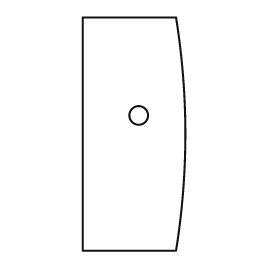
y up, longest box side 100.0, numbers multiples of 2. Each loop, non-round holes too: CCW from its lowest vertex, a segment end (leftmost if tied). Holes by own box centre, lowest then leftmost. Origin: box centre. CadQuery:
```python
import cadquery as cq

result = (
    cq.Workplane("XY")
    .moveTo(-22.0, -50.0)
    .lineTo(18.0, -50.0)
    .threePointArc((22.0, 0.0), (18.0, 50.0))
    .lineTo(-22.0, 50.0)
    .close()
    .moveTo(2.0, 8.0)
    .circle(4.0)
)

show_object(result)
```